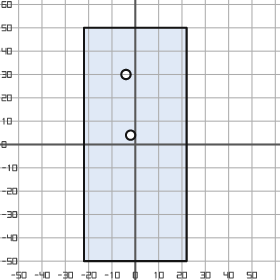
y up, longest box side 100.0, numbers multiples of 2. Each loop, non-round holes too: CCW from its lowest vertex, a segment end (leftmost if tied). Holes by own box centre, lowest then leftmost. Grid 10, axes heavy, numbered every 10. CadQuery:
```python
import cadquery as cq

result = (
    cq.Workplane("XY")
    .moveTo(-22.0, -50.0)
    .lineTo(22.0, -50.0)
    .lineTo(22.0, 50.0)
    .lineTo(-22.0, 50.0)
    .close()
    .moveTo(-2.0, 4.0)
    .circle(2.0)
    .moveTo(-4.0, 30.0)
    .circle(2.0)
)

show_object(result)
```